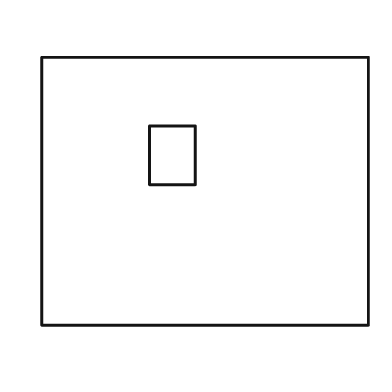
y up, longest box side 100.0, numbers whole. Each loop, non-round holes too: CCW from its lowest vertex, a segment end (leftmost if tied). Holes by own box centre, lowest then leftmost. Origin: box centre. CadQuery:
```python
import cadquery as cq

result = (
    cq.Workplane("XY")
    .moveTo(-50.0, -41.0)
    .lineTo(50.0, -41.0)
    .lineTo(50.0, 41.0)
    .lineTo(-50.0, 41.0)
    .close()
    .moveTo(-17.0, 2.0)
    .lineTo(-3.0, 2.0)
    .lineTo(-3.0, 20.0)
    .lineTo(-17.0, 20.0)
    .close()
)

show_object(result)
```